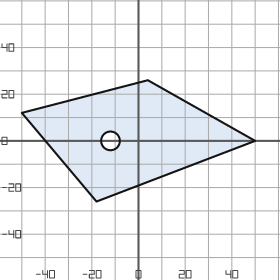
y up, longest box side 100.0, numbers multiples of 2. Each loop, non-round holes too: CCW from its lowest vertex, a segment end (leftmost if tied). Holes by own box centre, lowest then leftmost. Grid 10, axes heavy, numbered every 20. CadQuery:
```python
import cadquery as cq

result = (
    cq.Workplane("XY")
    .moveTo(-18.0, -26.0)
    .lineTo(50.0, 0.0)
    .lineTo(4.0, 26.0)
    .lineTo(-50.0, 12.0)
    .close()
    .moveTo(-12.0, 0.0)
    .circle(4.0)
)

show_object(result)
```